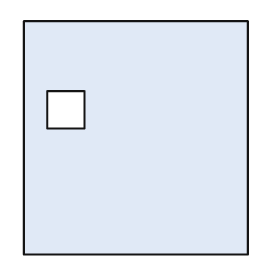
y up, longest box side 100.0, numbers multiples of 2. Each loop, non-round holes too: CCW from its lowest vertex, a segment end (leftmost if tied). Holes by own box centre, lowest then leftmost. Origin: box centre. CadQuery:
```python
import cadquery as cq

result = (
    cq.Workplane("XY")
    .moveTo(-48.0, -50.0)
    .lineTo(48.0, -50.0)
    .lineTo(48.0, 50.0)
    .lineTo(-48.0, 50.0)
    .close()
    .moveTo(-38.0, 4.0)
    .lineTo(-22.0, 4.0)
    .lineTo(-22.0, 20.0)
    .lineTo(-38.0, 20.0)
    .close()
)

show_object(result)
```